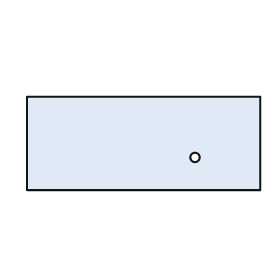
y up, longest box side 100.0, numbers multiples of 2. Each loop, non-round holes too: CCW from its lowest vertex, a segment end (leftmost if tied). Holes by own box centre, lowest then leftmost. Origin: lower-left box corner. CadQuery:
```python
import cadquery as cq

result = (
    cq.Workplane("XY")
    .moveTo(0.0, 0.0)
    .lineTo(100.0, 0.0)
    .lineTo(100.0, 40.0)
    .lineTo(0.0, 40.0)
    .close()
    .moveTo(72.0, 14.0)
    .circle(2.0)
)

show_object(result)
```